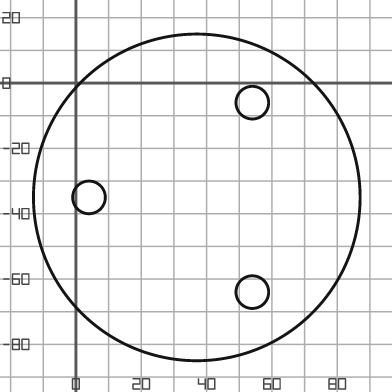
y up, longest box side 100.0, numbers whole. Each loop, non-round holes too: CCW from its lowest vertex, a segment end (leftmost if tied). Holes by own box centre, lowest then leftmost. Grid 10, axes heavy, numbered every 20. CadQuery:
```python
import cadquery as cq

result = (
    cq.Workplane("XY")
    .moveTo(37.0, -35.0)
    .circle(50.0)
    .moveTo(54.0, -64.0)
    .circle(5.0)
    .moveTo(4.0, -35.0)
    .circle(5.0)
    .moveTo(54.0, -6.0)
    .circle(5.0)
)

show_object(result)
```